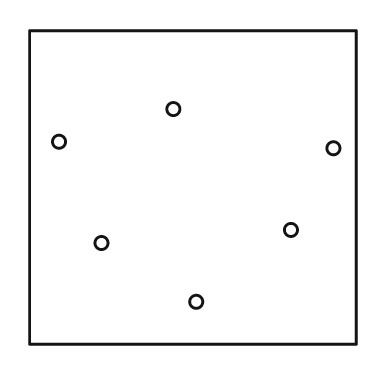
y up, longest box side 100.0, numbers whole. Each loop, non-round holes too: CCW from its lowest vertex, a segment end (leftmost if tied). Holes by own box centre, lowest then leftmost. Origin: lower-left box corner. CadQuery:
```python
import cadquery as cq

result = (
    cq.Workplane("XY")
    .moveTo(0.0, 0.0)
    .lineTo(100.0, 0.0)
    .lineTo(100.0, 96.0)
    .lineTo(0.0, 96.0)
    .close()
    .moveTo(51.0, 13.0)
    .circle(2.0)
    .moveTo(22.0, 31.0)
    .circle(2.0)
    .moveTo(80.0, 35.0)
    .circle(2.0)
    .moveTo(93.0, 60.0)
    .circle(2.0)
    .moveTo(9.0, 62.0)
    .circle(2.0)
    .moveTo(44.0, 72.0)
    .circle(2.0)
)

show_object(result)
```